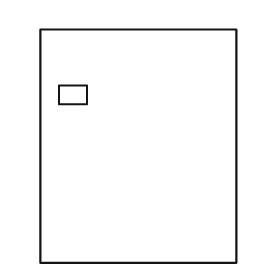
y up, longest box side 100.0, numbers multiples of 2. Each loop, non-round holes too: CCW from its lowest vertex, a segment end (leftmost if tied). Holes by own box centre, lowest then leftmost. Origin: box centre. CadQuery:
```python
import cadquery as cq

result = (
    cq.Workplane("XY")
    .moveTo(-42.0, -50.0)
    .lineTo(42.0, -50.0)
    .lineTo(42.0, 50.0)
    .lineTo(-42.0, 50.0)
    .close()
    .moveTo(-34.0, 18.0)
    .lineTo(-22.0, 18.0)
    .lineTo(-22.0, 26.0)
    .lineTo(-34.0, 26.0)
    .close()
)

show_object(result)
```